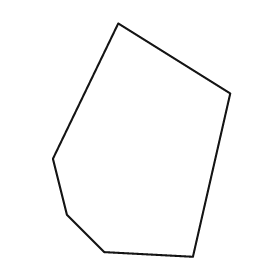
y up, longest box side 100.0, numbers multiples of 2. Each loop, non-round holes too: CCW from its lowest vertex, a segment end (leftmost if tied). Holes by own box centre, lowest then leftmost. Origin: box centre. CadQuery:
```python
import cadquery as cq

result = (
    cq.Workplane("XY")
    .moveTo(22.0, -50.0)
    .lineTo(38.0, 20.0)
    .lineTo(-10.0, 50.0)
    .lineTo(-38.0, -8.0)
    .lineTo(-32.0, -32.0)
    .lineTo(-16.0, -48.0)
    .close()
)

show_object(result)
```